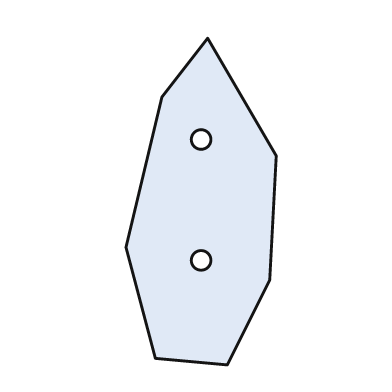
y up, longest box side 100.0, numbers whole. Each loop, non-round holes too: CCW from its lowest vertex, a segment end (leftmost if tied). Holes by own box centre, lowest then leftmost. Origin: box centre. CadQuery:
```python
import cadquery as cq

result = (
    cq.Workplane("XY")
    .moveTo(8.0, -50.0)
    .lineTo(21.0, -24.0)
    .lineTo(23.0, 14.0)
    .lineTo(2.0, 50.0)
    .lineTo(-12.0, 32.0)
    .lineTo(-23.0, -14.0)
    .lineTo(-14.0, -48.0)
    .close()
    .moveTo(0.0, -18.0)
    .circle(3.0)
    .moveTo(0.0, 19.0)
    .circle(3.0)
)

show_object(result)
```